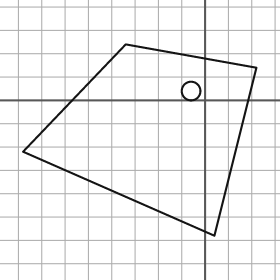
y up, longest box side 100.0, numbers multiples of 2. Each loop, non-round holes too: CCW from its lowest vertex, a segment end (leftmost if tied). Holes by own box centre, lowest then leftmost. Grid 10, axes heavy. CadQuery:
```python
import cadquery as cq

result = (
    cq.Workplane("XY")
    .moveTo(4.0, -58.0)
    .lineTo(22.0, 14.0)
    .lineTo(-34.0, 24.0)
    .lineTo(-78.0, -22.0)
    .close()
    .moveTo(-6.0, 4.0)
    .circle(4.0)
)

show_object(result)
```